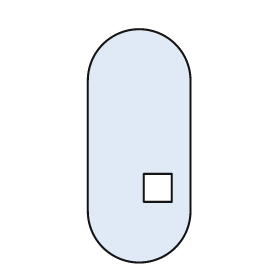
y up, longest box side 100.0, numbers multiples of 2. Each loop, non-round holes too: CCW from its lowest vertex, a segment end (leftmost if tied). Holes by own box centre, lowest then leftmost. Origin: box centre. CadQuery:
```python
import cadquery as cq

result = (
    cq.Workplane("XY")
    .moveTo(-22.0, -28.0)
    .threePointArc((0.0, -50.0), (22.0, -28.0))
    .lineTo(22.0, 28.0)
    .threePointArc((0.0, 50.0), (-22.0, 28.0))
    .close()
    .moveTo(2.0, -24.0)
    .lineTo(14.0, -24.0)
    .lineTo(14.0, -12.0)
    .lineTo(2.0, -12.0)
    .close()
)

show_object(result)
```